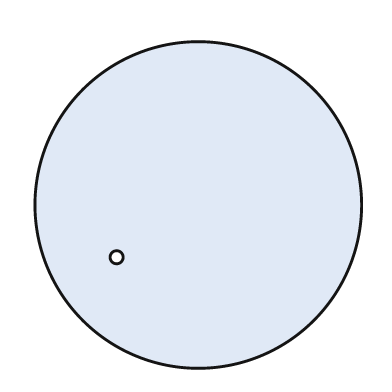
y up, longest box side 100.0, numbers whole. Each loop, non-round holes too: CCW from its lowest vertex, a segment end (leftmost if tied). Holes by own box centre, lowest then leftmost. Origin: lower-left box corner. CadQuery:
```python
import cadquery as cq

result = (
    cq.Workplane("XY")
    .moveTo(50.0, 50.0)
    .circle(50.0)
    .moveTo(25.0, 34.0)
    .circle(2.0)
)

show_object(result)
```